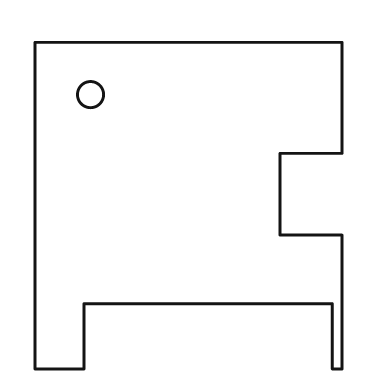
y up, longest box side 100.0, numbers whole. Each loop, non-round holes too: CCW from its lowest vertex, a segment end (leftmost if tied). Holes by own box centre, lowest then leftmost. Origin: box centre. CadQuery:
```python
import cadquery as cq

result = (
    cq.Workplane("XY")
    .moveTo(-47.0, -50.0)
    .lineTo(-32.0, -50.0)
    .lineTo(-32.0, -30.0)
    .lineTo(44.0, -30.0)
    .lineTo(44.0, -50.0)
    .lineTo(47.0, -50.0)
    .lineTo(47.0, -9.0)
    .lineTo(28.0, -9.0)
    .lineTo(28.0, 16.0)
    .lineTo(47.0, 16.0)
    .lineTo(47.0, 50.0)
    .lineTo(-47.0, 50.0)
    .close()
    .moveTo(-30.0, 34.0)
    .circle(4.0)
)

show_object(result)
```